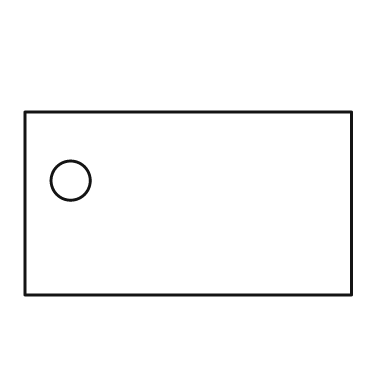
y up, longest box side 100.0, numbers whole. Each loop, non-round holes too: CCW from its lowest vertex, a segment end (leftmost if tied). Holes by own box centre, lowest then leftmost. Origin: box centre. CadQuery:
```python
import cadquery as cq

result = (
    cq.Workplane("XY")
    .moveTo(-50.0, -28.0)
    .lineTo(50.0, -28.0)
    .lineTo(50.0, 28.0)
    .lineTo(-50.0, 28.0)
    .close()
    .moveTo(-36.0, 7.0)
    .circle(6.0)
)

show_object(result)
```